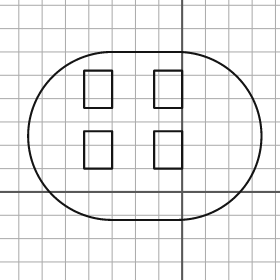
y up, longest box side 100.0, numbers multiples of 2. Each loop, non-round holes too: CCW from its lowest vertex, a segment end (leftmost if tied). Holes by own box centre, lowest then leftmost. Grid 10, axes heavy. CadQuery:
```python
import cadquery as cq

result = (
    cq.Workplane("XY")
    .moveTo(-30.0, -12.0)
    .lineTo(-2.0, -12.0)
    .threePointArc((34.0, 24.0), (-2.0, 60.0))
    .lineTo(-30.0, 60.0)
    .threePointArc((-66.0, 24.0), (-30.0, -12.0))
    .close()
    .moveTo(-42.0, 10.0)
    .lineTo(-30.0, 10.0)
    .lineTo(-30.0, 26.0)
    .lineTo(-42.0, 26.0)
    .close()
    .moveTo(-12.0, 10.0)
    .lineTo(0.0, 10.0)
    .lineTo(0.0, 26.0)
    .lineTo(-12.0, 26.0)
    .close()
    .moveTo(-42.0, 36.0)
    .lineTo(-30.0, 36.0)
    .lineTo(-30.0, 52.0)
    .lineTo(-42.0, 52.0)
    .close()
    .moveTo(-12.0, 36.0)
    .lineTo(0.0, 36.0)
    .lineTo(0.0, 52.0)
    .lineTo(-12.0, 52.0)
    .close()
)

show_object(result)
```